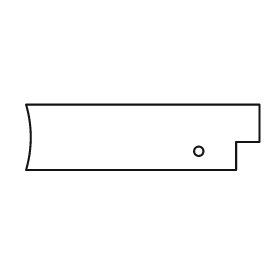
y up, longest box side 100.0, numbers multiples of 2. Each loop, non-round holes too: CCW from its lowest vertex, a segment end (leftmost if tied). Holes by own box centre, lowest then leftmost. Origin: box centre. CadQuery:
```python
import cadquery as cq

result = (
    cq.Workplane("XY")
    .moveTo(-50.0, -14.0)
    .lineTo(40.0, -14.0)
    .lineTo(40.0, -2.0)
    .lineTo(50.0, -2.0)
    .lineTo(50.0, 14.0)
    .lineTo(-50.0, 14.0)
    .threePointArc((-48.0, 0.0), (-50.0, -14.0))
    .close()
    .moveTo(24.0, -6.0)
    .circle(2.0)
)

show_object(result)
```